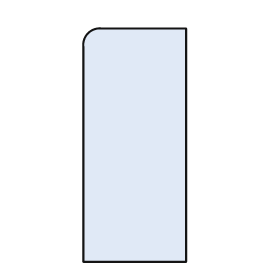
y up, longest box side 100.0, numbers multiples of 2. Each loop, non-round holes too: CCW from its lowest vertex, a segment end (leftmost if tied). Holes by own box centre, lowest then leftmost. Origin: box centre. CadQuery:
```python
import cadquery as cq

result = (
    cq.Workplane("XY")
    .moveTo(-22.0, -50.0)
    .lineTo(22.0, -50.0)
    .lineTo(22.0, 50.0)
    .lineTo(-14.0, 50.0)
    .threePointArc((-20.0, 48.0), (-22.0, 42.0))
    .close()
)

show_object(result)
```